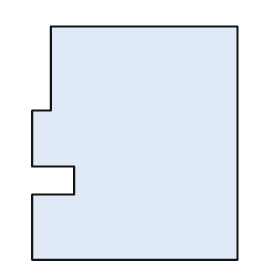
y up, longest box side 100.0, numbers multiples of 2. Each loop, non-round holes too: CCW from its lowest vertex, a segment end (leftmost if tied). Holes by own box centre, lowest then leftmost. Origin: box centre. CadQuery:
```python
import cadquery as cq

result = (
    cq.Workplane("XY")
    .moveTo(-44.0, -50.0)
    .lineTo(44.0, -50.0)
    .lineTo(44.0, 50.0)
    .lineTo(-36.0, 50.0)
    .lineTo(-36.0, 14.0)
    .lineTo(-44.0, 14.0)
    .lineTo(-44.0, -10.0)
    .lineTo(-26.0, -10.0)
    .lineTo(-26.0, -22.0)
    .lineTo(-44.0, -22.0)
    .close()
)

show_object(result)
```